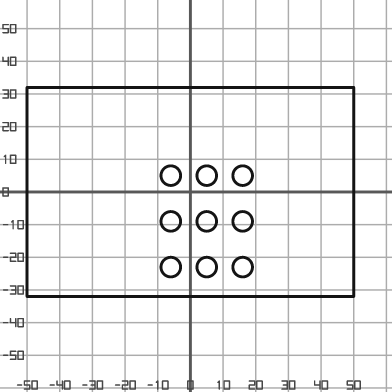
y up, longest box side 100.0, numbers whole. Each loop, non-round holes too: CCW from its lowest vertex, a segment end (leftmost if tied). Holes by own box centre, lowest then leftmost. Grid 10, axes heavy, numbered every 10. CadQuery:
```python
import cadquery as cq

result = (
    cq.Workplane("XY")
    .moveTo(-50.0, -32.0)
    .lineTo(50.0, -32.0)
    .lineTo(50.0, 32.0)
    .lineTo(-50.0, 32.0)
    .close()
    .moveTo(-6.0, -23.0)
    .circle(3.0)
    .moveTo(5.0, -23.0)
    .circle(3.0)
    .moveTo(16.0, -23.0)
    .circle(3.0)
    .moveTo(-6.0, -9.0)
    .circle(3.0)
    .moveTo(5.0, -9.0)
    .circle(3.0)
    .moveTo(16.0, -9.0)
    .circle(3.0)
    .moveTo(-6.0, 5.0)
    .circle(3.0)
    .moveTo(5.0, 5.0)
    .circle(3.0)
    .moveTo(16.0, 5.0)
    .circle(3.0)
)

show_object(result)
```